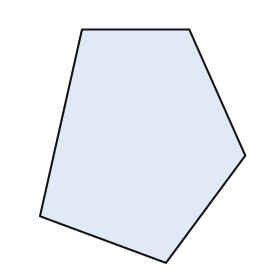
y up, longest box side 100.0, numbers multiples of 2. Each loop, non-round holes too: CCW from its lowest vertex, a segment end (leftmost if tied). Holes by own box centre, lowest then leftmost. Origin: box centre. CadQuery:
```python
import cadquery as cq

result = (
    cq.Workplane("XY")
    .moveTo(10.0, -50.0)
    .lineTo(44.0, -4.0)
    .lineTo(20.0, 50.0)
    .lineTo(-26.0, 50.0)
    .lineTo(-44.0, -30.0)
    .close()
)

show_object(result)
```